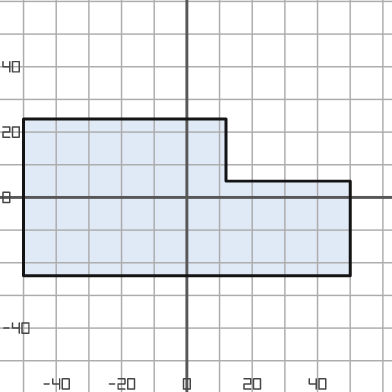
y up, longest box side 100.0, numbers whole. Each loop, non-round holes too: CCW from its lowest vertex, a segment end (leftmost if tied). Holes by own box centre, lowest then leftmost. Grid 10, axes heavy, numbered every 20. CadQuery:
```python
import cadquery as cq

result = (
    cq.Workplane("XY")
    .moveTo(-50.0, -24.0)
    .lineTo(50.0, -24.0)
    .lineTo(50.0, 5.0)
    .lineTo(12.0, 5.0)
    .lineTo(12.0, 24.0)
    .lineTo(-50.0, 24.0)
    .close()
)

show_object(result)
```